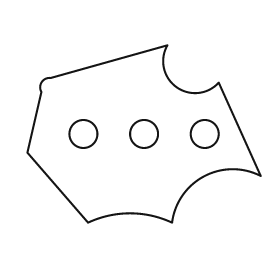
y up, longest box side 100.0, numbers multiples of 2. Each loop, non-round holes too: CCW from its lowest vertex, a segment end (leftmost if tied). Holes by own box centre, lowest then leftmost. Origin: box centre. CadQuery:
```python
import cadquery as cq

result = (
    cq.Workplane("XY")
    .moveTo(-24.0, -38.0)
    .threePointArc((-6.0, -34.0), (12.0, -38.0))
    .threePointArc((26.0, -18.0), (50.0, -18.0))
    .lineTo(32.0, 22.0)
    .threePointArc((14.0, 20.0), (10.0, 38.0))
    .lineTo(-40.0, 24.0)
    .threePointArc((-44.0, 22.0), (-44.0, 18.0))
    .lineTo(-50.0, -8.0)
    .close()
    .moveTo(-26.0, 0.0)
    .circle(6.0)
    .moveTo(0.0, 0.0)
    .circle(6.0)
    .moveTo(26.0, 0.0)
    .circle(6.0)
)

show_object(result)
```